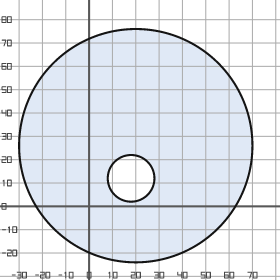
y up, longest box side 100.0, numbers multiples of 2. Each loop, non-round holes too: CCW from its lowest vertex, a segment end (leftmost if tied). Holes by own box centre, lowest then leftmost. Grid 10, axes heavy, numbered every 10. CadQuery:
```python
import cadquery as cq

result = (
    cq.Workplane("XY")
    .moveTo(20.0, 26.0)
    .circle(50.0)
    .moveTo(18.0, 12.0)
    .circle(10.0)
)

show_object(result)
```